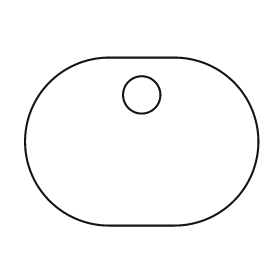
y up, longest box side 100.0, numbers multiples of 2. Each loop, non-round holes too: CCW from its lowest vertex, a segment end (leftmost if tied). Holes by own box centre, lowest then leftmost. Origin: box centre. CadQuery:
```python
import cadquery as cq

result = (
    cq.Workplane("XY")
    .moveTo(-14.0, -36.0)
    .lineTo(14.0, -36.0)
    .threePointArc((50.0, 0.0), (14.0, 36.0))
    .lineTo(-14.0, 36.0)
    .threePointArc((-50.0, 0.0), (-14.0, -36.0))
    .close()
    .moveTo(0.0, 20.0)
    .circle(8.0)
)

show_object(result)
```